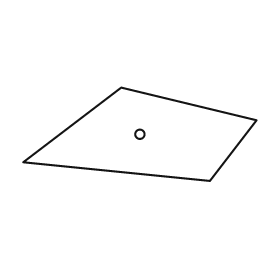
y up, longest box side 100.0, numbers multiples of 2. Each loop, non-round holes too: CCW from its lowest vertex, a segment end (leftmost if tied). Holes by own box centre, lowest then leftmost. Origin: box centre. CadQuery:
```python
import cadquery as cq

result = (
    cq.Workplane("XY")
    .moveTo(30.0, -20.0)
    .lineTo(50.0, 6.0)
    .lineTo(-8.0, 20.0)
    .lineTo(-50.0, -12.0)
    .close()
    .moveTo(0.0, 0.0)
    .circle(2.0)
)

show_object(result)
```